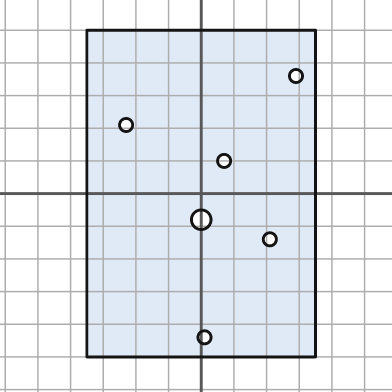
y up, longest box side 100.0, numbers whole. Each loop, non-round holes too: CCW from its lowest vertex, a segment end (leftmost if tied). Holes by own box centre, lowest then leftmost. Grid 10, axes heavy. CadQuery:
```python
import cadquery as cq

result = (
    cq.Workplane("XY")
    .moveTo(-35.0, -50.0)
    .lineTo(35.0, -50.0)
    .lineTo(35.0, 50.0)
    .lineTo(-35.0, 50.0)
    .close()
    .moveTo(1.0, -44.0)
    .circle(2.0)
    .moveTo(21.0, -14.0)
    .circle(2.0)
    .moveTo(0.0, -8.0)
    .circle(3.0)
    .moveTo(7.0, 10.0)
    .circle(2.0)
    .moveTo(-23.0, 21.0)
    .circle(2.0)
    .moveTo(29.0, 36.0)
    .circle(2.0)
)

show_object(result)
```